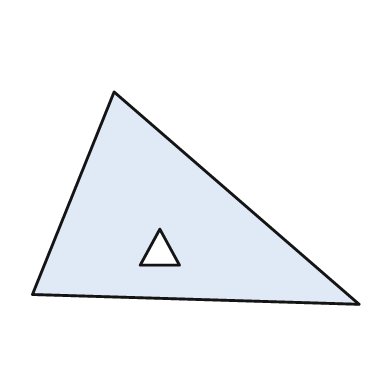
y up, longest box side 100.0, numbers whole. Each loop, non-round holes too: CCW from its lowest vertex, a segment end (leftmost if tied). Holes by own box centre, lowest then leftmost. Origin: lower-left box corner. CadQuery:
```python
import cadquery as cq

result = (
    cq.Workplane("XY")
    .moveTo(100.0, 0.0)
    .lineTo(25.0, 65.0)
    .lineTo(0.0, 3.0)
    .close()
    .moveTo(33.0, 12.0)
    .lineTo(45.0, 12.0)
    .lineTo(39.0, 23.0)
    .close()
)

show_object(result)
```